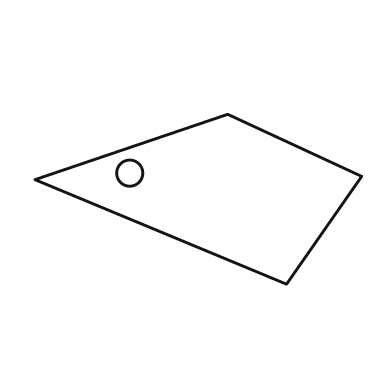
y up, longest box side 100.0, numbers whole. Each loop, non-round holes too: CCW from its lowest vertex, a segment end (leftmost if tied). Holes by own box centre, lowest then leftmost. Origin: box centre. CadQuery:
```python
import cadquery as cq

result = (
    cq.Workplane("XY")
    .moveTo(27.0, -26.0)
    .lineTo(50.0, 7.0)
    .lineTo(9.0, 26.0)
    .lineTo(-50.0, 6.0)
    .close()
    .moveTo(-21.0, 8.0)
    .circle(4.0)
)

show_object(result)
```